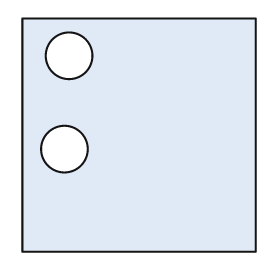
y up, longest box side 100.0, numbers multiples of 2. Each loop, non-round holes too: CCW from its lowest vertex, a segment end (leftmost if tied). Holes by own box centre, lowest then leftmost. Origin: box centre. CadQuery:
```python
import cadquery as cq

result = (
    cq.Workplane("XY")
    .moveTo(-50.0, -50.0)
    .lineTo(50.0, -50.0)
    .lineTo(50.0, 50.0)
    .lineTo(-50.0, 50.0)
    .close()
    .moveTo(-32.0, -6.0)
    .circle(10.0)
    .moveTo(-30.0, 34.0)
    .circle(10.0)
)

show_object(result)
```